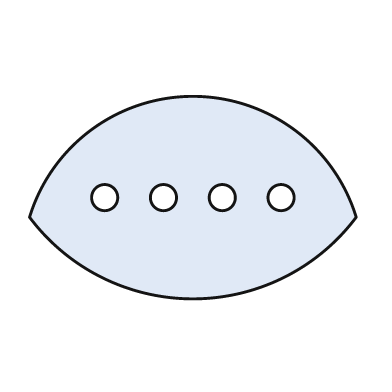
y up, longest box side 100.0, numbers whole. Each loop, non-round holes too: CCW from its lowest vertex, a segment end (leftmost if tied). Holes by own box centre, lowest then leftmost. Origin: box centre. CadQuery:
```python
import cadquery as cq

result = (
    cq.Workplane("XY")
    .moveTo(-50.0, -6.0)
    .threePointArc((0.0, -31.0), (50.0, -6.0))
    .threePointArc((0.0, 31.0), (-50.0, -6.0))
    .close()
    .moveTo(-27.0, 0.0)
    .circle(4.0)
    .moveTo(-9.0, 0.0)
    .circle(4.0)
    .moveTo(9.0, 0.0)
    .circle(4.0)
    .moveTo(27.0, 0.0)
    .circle(4.0)
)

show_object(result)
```